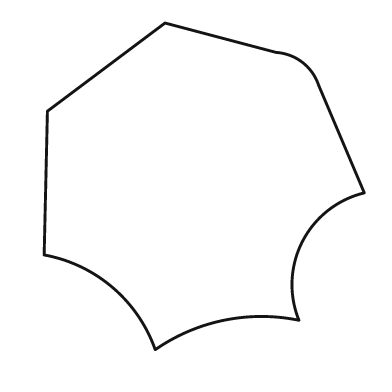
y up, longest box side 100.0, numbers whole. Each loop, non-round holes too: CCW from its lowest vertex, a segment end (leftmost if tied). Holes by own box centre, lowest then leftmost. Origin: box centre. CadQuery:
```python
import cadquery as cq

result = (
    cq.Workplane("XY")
    .moveTo(-15.0, -50.0)
    .threePointArc((6.0, -41.0), (29.0, -41.0))
    .threePointArc((30.0, -17.0), (49.0, -2.0))
    .lineTo(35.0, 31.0)
    .threePointArc((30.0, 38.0), (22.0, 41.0))
    .lineTo(-12.0, 50.0)
    .lineTo(-48.0, 23.0)
    .lineTo(-49.0, -21.0)
    .threePointArc((-28.0, -31.0), (-15.0, -50.0))
    .close()
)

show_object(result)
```